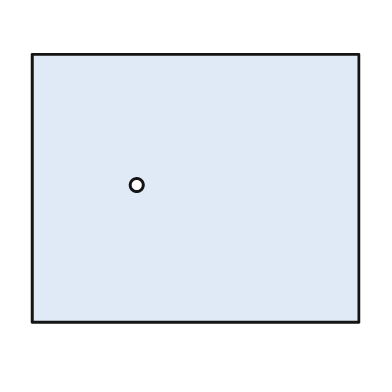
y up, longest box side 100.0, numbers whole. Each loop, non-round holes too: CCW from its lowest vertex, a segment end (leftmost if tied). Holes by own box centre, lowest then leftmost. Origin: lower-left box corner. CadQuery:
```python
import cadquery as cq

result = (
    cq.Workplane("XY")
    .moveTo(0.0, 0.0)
    .lineTo(100.0, 0.0)
    .lineTo(100.0, 82.0)
    .lineTo(0.0, 82.0)
    .close()
    .moveTo(32.0, 42.0)
    .circle(2.0)
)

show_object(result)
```